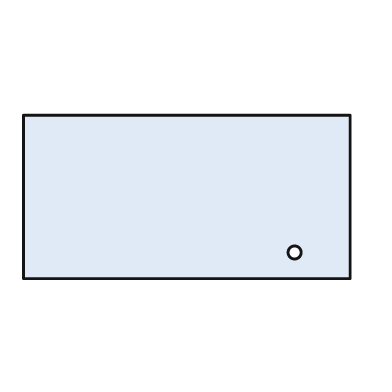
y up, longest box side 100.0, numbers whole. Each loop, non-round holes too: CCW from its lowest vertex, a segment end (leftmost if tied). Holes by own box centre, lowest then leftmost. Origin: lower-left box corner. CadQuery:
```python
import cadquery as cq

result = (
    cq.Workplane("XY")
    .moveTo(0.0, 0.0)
    .lineTo(100.0, 0.0)
    .lineTo(100.0, 50.0)
    .lineTo(0.0, 50.0)
    .close()
    .moveTo(83.0, 8.0)
    .circle(2.0)
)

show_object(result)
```